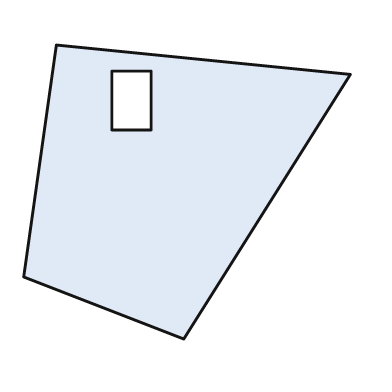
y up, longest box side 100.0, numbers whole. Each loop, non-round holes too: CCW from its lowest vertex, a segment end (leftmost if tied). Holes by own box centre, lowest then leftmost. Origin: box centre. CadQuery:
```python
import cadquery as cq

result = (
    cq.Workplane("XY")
    .moveTo(-1.0, -45.0)
    .lineTo(50.0, 36.0)
    .lineTo(-40.0, 45.0)
    .lineTo(-50.0, -26.0)
    .close()
    .moveTo(-23.0, 19.0)
    .lineTo(-11.0, 19.0)
    .lineTo(-11.0, 37.0)
    .lineTo(-23.0, 37.0)
    .close()
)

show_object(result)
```